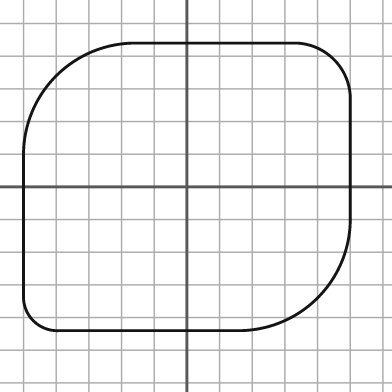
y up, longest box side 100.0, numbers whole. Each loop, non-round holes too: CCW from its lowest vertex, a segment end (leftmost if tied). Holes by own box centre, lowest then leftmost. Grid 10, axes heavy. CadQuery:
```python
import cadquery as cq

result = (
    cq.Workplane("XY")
    .moveTo(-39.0, -44.0)
    .lineTo(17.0, -44.0)
    .threePointArc((40.0, -34.0), (50.0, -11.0))
    .lineTo(50.0, 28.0)
    .threePointArc((45.0, 39.0), (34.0, 44.0))
    .lineTo(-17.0, 44.0)
    .threePointArc((-40.0, 34.0), (-50.0, 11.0))
    .lineTo(-50.0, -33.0)
    .threePointArc((-47.0, -41.0), (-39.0, -44.0))
    .close()
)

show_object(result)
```